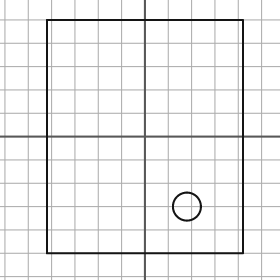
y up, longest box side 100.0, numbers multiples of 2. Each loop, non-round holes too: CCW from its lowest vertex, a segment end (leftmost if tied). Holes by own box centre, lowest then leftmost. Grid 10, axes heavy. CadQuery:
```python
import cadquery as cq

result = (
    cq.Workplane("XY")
    .moveTo(-42.0, -50.0)
    .lineTo(42.0, -50.0)
    .lineTo(42.0, 50.0)
    .lineTo(-42.0, 50.0)
    .close()
    .moveTo(18.0, -30.0)
    .circle(6.0)
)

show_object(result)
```